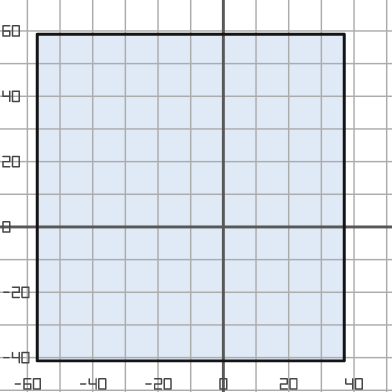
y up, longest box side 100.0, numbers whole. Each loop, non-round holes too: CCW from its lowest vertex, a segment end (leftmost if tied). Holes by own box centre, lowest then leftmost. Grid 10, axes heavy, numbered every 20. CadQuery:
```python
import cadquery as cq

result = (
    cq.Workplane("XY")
    .moveTo(-57.0, -41.0)
    .lineTo(37.0, -41.0)
    .lineTo(37.0, 59.0)
    .lineTo(-57.0, 59.0)
    .close()
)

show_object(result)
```